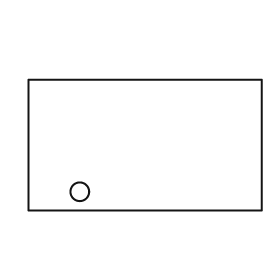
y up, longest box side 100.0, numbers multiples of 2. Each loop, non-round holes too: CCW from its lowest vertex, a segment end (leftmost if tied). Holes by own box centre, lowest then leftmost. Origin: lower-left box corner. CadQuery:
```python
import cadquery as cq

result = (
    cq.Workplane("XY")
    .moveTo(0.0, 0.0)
    .lineTo(100.0, 0.0)
    .lineTo(100.0, 56.0)
    .lineTo(0.0, 56.0)
    .close()
    .moveTo(22.0, 8.0)
    .circle(4.0)
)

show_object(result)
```